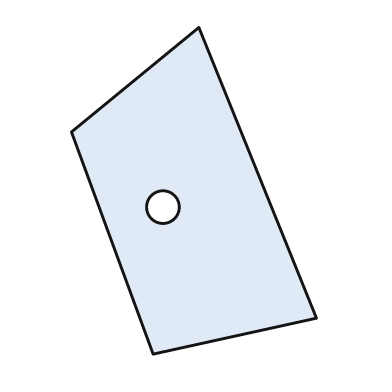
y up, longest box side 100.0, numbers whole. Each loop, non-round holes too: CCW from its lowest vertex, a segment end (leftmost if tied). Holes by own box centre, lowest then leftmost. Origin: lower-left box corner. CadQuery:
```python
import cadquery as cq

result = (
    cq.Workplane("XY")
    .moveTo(25.0, 0.0)
    .lineTo(75.0, 11.0)
    .lineTo(39.0, 100.0)
    .lineTo(0.0, 68.0)
    .close()
    .moveTo(28.0, 45.0)
    .circle(5.0)
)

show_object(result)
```